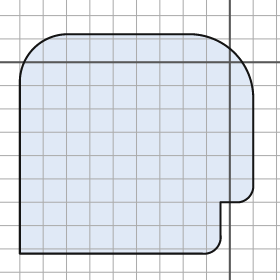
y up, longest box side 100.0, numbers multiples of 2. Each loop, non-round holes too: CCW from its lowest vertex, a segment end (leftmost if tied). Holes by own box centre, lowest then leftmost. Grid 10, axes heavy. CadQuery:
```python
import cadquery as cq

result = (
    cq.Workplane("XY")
    .moveTo(-90.0, -82.0)
    .lineTo(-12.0, -82.0)
    .threePointArc((-6.0, -80.0), (-4.0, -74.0))
    .lineTo(-4.0, -60.0)
    .lineTo(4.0, -60.0)
    .threePointArc((8.0, -58.0), (10.0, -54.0))
    .lineTo(10.0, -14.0)
    .threePointArc((2.0, 4.0), (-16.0, 12.0))
    .lineTo(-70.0, 12.0)
    .threePointArc((-84.0, 6.0), (-90.0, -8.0))
    .close()
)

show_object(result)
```